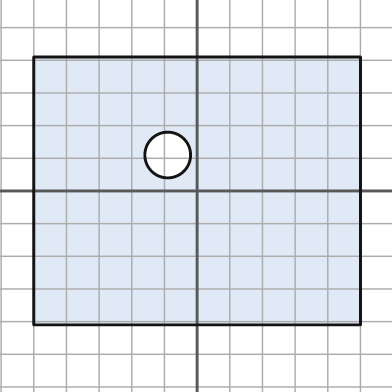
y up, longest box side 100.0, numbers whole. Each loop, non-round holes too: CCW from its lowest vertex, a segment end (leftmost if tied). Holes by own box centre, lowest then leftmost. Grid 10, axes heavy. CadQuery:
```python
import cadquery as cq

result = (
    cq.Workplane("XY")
    .moveTo(-50.0, -41.0)
    .lineTo(50.0, -41.0)
    .lineTo(50.0, 41.0)
    .lineTo(-50.0, 41.0)
    .close()
    .moveTo(-9.0, 11.0)
    .circle(7.0)
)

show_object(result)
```